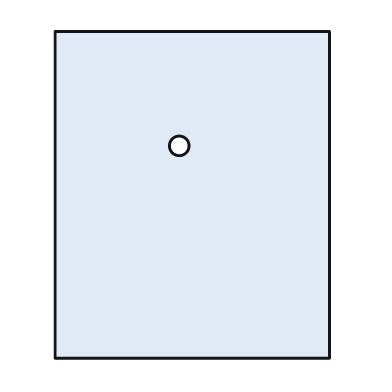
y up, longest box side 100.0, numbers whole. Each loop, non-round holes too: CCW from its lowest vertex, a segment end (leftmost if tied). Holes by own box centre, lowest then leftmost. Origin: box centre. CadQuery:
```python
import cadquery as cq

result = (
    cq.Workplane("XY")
    .moveTo(-42.0, -50.0)
    .lineTo(42.0, -50.0)
    .lineTo(42.0, 50.0)
    .lineTo(-42.0, 50.0)
    .close()
    .moveTo(-4.0, 15.0)
    .circle(3.0)
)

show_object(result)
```